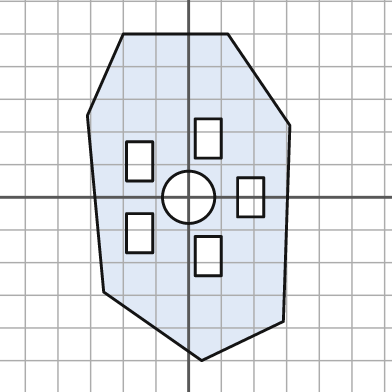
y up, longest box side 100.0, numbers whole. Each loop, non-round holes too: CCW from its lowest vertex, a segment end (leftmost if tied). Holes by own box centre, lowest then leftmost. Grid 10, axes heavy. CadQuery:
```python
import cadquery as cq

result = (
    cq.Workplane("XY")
    .moveTo(4.0, -50.0)
    .lineTo(29.0, -38.0)
    .lineTo(31.0, 22.0)
    .lineTo(12.0, 50.0)
    .lineTo(-20.0, 50.0)
    .lineTo(-31.0, 25.0)
    .lineTo(-26.0, -29.0)
    .close()
    .moveTo(2.0, -24.0)
    .lineTo(10.0, -24.0)
    .lineTo(10.0, -12.0)
    .lineTo(2.0, -12.0)
    .close()
    .moveTo(-19.0, -17.0)
    .lineTo(-11.0, -17.0)
    .lineTo(-11.0, -5.0)
    .lineTo(-19.0, -5.0)
    .close()
    .moveTo(0.0, 0.0)
    .circle(8.0)
    .moveTo(15.0, -6.0)
    .lineTo(23.0, -6.0)
    .lineTo(23.0, 6.0)
    .lineTo(15.0, 6.0)
    .close()
    .moveTo(-19.0, 5.0)
    .lineTo(-11.0, 5.0)
    .lineTo(-11.0, 17.0)
    .lineTo(-19.0, 17.0)
    .close()
    .moveTo(2.0, 12.0)
    .lineTo(10.0, 12.0)
    .lineTo(10.0, 24.0)
    .lineTo(2.0, 24.0)
    .close()
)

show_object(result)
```